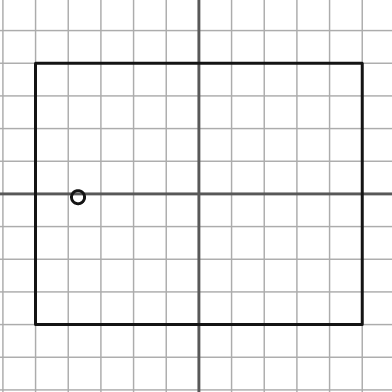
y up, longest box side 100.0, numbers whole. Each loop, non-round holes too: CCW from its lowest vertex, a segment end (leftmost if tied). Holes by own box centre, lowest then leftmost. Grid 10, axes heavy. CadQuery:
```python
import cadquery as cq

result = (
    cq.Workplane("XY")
    .moveTo(-50.0, -40.0)
    .lineTo(50.0, -40.0)
    .lineTo(50.0, 40.0)
    .lineTo(-50.0, 40.0)
    .close()
    .moveTo(-37.0, -1.0)
    .circle(2.0)
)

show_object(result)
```